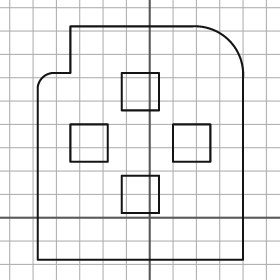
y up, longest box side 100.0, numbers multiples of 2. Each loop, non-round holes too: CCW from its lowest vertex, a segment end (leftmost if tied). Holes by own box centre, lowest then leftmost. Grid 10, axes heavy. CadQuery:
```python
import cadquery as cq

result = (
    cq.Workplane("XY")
    .moveTo(-48.0, -18.0)
    .lineTo(40.0, -18.0)
    .lineTo(40.0, 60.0)
    .threePointArc((34.0, 76.0), (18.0, 82.0))
    .lineTo(-34.0, 82.0)
    .lineTo(-34.0, 62.0)
    .lineTo(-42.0, 62.0)
    .threePointArc((-46.0, 60.0), (-48.0, 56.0))
    .close()
    .moveTo(-12.0, 2.0)
    .lineTo(4.0, 2.0)
    .lineTo(4.0, 18.0)
    .lineTo(-12.0, 18.0)
    .close()
    .moveTo(-34.0, 24.0)
    .lineTo(-18.0, 24.0)
    .lineTo(-18.0, 40.0)
    .lineTo(-34.0, 40.0)
    .close()
    .moveTo(10.0, 24.0)
    .lineTo(26.0, 24.0)
    .lineTo(26.0, 40.0)
    .lineTo(10.0, 40.0)
    .close()
    .moveTo(-12.0, 46.0)
    .lineTo(4.0, 46.0)
    .lineTo(4.0, 62.0)
    .lineTo(-12.0, 62.0)
    .close()
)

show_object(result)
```